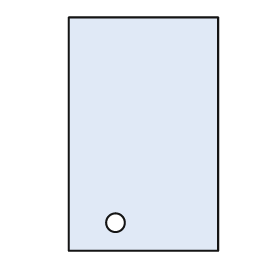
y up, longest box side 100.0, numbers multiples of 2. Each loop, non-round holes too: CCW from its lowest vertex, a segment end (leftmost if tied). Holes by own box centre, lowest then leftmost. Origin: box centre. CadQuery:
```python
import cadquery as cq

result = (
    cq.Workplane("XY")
    .moveTo(-32.0, -50.0)
    .lineTo(32.0, -50.0)
    .lineTo(32.0, 50.0)
    .lineTo(-32.0, 50.0)
    .close()
    .moveTo(-12.0, -38.0)
    .circle(4.0)
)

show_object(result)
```